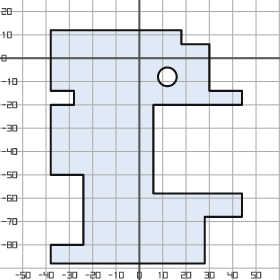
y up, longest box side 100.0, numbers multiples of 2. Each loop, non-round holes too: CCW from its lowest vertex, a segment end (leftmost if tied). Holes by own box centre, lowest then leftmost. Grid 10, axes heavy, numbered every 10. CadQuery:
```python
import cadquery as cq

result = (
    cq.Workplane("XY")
    .moveTo(-38.0, -88.0)
    .lineTo(28.0, -88.0)
    .lineTo(28.0, -68.0)
    .lineTo(44.0, -68.0)
    .lineTo(44.0, -58.0)
    .lineTo(6.0, -58.0)
    .lineTo(6.0, -20.0)
    .lineTo(44.0, -20.0)
    .lineTo(44.0, -14.0)
    .lineTo(30.0, -14.0)
    .lineTo(30.0, 6.0)
    .lineTo(18.0, 6.0)
    .lineTo(18.0, 12.0)
    .lineTo(-38.0, 12.0)
    .lineTo(-38.0, -14.0)
    .lineTo(-28.0, -14.0)
    .lineTo(-28.0, -20.0)
    .lineTo(-38.0, -20.0)
    .lineTo(-38.0, -50.0)
    .lineTo(-24.0, -50.0)
    .lineTo(-24.0, -80.0)
    .lineTo(-38.0, -80.0)
    .close()
    .moveTo(12.0, -8.0)
    .circle(4.0)
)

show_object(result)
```